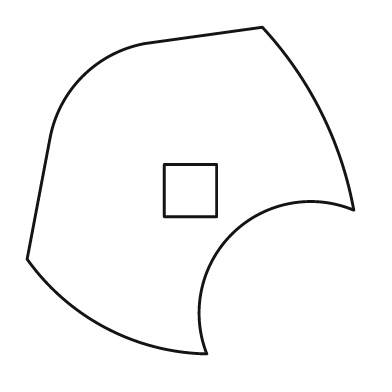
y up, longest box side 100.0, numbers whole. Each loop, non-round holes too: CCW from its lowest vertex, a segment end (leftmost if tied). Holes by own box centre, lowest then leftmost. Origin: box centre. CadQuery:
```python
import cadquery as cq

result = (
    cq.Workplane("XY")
    .moveTo(5.0, -50.0)
    .threePointArc((13.0, -13.0), (50.0, -6.0))
    .threePointArc((40.0, 24.0), (22.0, 50.0))
    .lineTo(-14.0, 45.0)
    .threePointArc((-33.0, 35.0), (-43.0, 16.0))
    .lineTo(-50.0, -21.0)
    .threePointArc((-26.0, -42.0), (5.0, -50.0))
    .close()
    .moveTo(-8.0, -8.0)
    .lineTo(8.0, -8.0)
    .lineTo(8.0, 8.0)
    .lineTo(-8.0, 8.0)
    .close()
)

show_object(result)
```